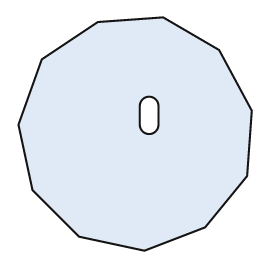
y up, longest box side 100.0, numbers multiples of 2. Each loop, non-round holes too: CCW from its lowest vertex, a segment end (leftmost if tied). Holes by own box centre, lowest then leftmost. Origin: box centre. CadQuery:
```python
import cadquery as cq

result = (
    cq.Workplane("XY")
    .moveTo(4.0, -50.0)
    .lineTo(30.0, -40.0)
    .lineTo(48.0, -18.0)
    .lineTo(50.0, 10.0)
    .lineTo(36.0, 36.0)
    .lineTo(12.0, 50.0)
    .lineTo(-16.0, 48.0)
    .lineTo(-40.0, 32.0)
    .lineTo(-50.0, 4.0)
    .lineTo(-44.0, -24.0)
    .lineTo(-24.0, -44.0)
    .close()
    .moveTo(2.0, 4.0)
    .threePointArc((6.0, 0.0), (10.0, 4.0))
    .lineTo(10.0, 12.0)
    .threePointArc((6.0, 16.0), (2.0, 12.0))
    .close()
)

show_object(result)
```